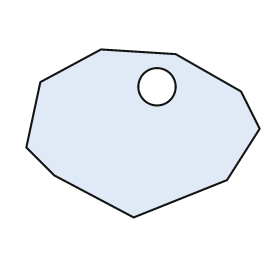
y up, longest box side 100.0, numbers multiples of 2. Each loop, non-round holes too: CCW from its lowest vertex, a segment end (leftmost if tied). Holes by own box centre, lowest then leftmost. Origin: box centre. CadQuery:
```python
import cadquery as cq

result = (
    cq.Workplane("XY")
    .moveTo(-4.0, -36.0)
    .lineTo(36.0, -20.0)
    .lineTo(50.0, 2.0)
    .lineTo(42.0, 18.0)
    .lineTo(14.0, 34.0)
    .lineTo(-18.0, 36.0)
    .lineTo(-44.0, 22.0)
    .lineTo(-50.0, -6.0)
    .lineTo(-38.0, -18.0)
    .close()
    .moveTo(6.0, 20.0)
    .circle(8.0)
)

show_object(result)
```